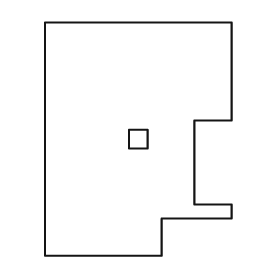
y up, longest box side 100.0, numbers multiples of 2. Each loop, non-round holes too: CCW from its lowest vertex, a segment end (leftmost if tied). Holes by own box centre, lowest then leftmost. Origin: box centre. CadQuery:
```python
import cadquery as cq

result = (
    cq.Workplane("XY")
    .moveTo(-40.0, -50.0)
    .lineTo(10.0, -50.0)
    .lineTo(10.0, -34.0)
    .lineTo(40.0, -34.0)
    .lineTo(40.0, -28.0)
    .lineTo(24.0, -28.0)
    .lineTo(24.0, 8.0)
    .lineTo(40.0, 8.0)
    .lineTo(40.0, 50.0)
    .lineTo(-40.0, 50.0)
    .close()
    .moveTo(-4.0, -4.0)
    .lineTo(4.0, -4.0)
    .lineTo(4.0, 4.0)
    .lineTo(-4.0, 4.0)
    .close()
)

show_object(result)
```